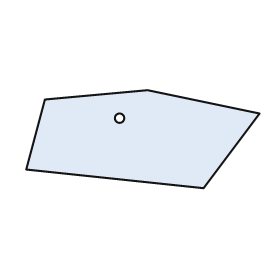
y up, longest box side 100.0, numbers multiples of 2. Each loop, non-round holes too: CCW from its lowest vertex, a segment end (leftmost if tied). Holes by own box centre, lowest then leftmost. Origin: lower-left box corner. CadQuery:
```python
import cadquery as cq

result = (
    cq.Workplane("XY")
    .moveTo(76.0, 0.0)
    .lineTo(100.0, 32.0)
    .lineTo(52.0, 42.0)
    .lineTo(8.0, 38.0)
    .lineTo(0.0, 8.0)
    .close()
    .moveTo(40.0, 30.0)
    .circle(2.0)
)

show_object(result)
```